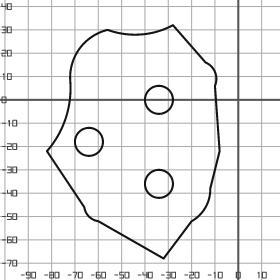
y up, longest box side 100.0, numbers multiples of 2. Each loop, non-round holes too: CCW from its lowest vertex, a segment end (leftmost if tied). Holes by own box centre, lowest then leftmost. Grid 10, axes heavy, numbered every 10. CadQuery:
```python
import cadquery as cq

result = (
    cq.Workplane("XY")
    .moveTo(-32.0, -68.0)
    .lineTo(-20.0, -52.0)
    .threePointArc((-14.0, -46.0), (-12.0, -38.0))
    .lineTo(-8.0, -22.0)
    .lineTo(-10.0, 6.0)
    .threePointArc((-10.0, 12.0), (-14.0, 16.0))
    .lineTo(-28.0, 32.0)
    .threePointArc((-42.0, 28.0), (-56.0, 30.0))
    .threePointArc((-68.0, 22.0), (-72.0, 8.0))
    .threePointArc((-74.0, -8.0), (-82.0, -22.0))
    .lineTo(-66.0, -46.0)
    .threePointArc((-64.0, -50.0), (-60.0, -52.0))
    .close()
    .moveTo(-34.0, -36.0)
    .circle(6.0)
    .moveTo(-64.0, -18.0)
    .circle(6.0)
    .moveTo(-34.0, 0.0)
    .circle(6.0)
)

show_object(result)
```